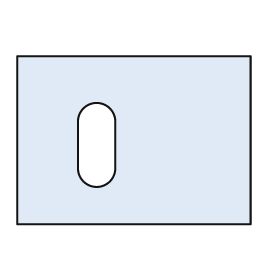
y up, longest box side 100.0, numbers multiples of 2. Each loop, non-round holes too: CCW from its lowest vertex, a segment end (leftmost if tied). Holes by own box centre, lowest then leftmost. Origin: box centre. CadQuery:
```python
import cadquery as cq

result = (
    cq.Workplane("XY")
    .moveTo(-50.0, -36.0)
    .lineTo(50.0, -36.0)
    .lineTo(50.0, 36.0)
    .lineTo(-50.0, 36.0)
    .close()
    .moveTo(-24.0, -12.0)
    .threePointArc((-16.0, -20.0), (-8.0, -12.0))
    .lineTo(-8.0, 8.0)
    .threePointArc((-16.0, 16.0), (-24.0, 8.0))
    .close()
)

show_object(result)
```